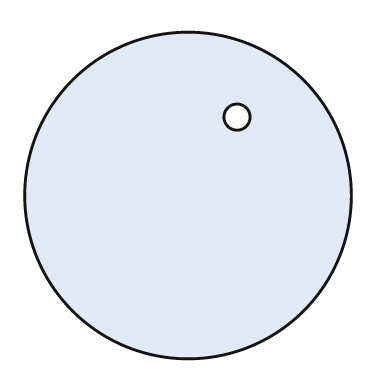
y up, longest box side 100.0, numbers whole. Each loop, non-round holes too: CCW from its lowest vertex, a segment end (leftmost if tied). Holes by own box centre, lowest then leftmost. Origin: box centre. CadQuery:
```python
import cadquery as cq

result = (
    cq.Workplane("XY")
    .moveTo(0.0, 0.0)
    .circle(50.0)
    .moveTo(15.0, 24.0)
    .circle(4.0)
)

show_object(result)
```